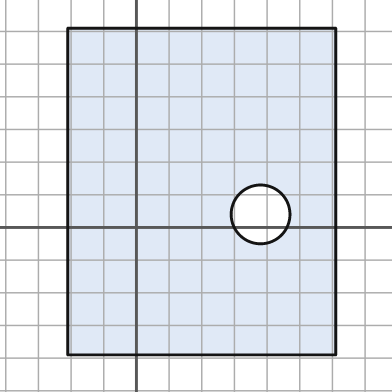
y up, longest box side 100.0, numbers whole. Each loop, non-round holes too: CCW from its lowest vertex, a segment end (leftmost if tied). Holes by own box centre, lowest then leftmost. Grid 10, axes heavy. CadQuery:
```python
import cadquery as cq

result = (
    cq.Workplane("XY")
    .moveTo(-21.0, -39.0)
    .lineTo(61.0, -39.0)
    .lineTo(61.0, 61.0)
    .lineTo(-21.0, 61.0)
    .close()
    .moveTo(38.0, 4.0)
    .circle(9.0)
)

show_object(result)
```